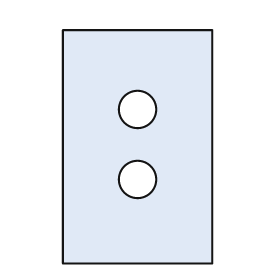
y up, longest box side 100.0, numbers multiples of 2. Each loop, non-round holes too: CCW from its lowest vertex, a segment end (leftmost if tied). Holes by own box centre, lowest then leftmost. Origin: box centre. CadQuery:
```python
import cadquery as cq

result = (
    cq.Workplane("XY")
    .moveTo(-32.0, -50.0)
    .lineTo(32.0, -50.0)
    .lineTo(32.0, 50.0)
    .lineTo(-32.0, 50.0)
    .close()
    .moveTo(0.0, -14.0)
    .circle(8.0)
    .moveTo(0.0, 16.0)
    .circle(8.0)
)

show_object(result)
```